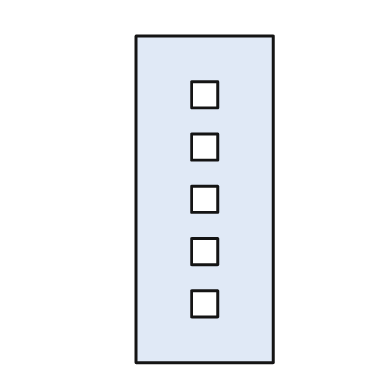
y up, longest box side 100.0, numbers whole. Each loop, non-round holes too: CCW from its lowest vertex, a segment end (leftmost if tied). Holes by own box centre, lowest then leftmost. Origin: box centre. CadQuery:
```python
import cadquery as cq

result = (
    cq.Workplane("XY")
    .moveTo(-21.0, -50.0)
    .lineTo(21.0, -50.0)
    .lineTo(21.0, 50.0)
    .lineTo(-21.0, 50.0)
    .close()
    .moveTo(-4.0, -36.0)
    .lineTo(4.0, -36.0)
    .lineTo(4.0, -28.0)
    .lineTo(-4.0, -28.0)
    .close()
    .moveTo(-4.0, -20.0)
    .lineTo(4.0, -20.0)
    .lineTo(4.0, -12.0)
    .lineTo(-4.0, -12.0)
    .close()
    .moveTo(-4.0, -4.0)
    .lineTo(4.0, -4.0)
    .lineTo(4.0, 4.0)
    .lineTo(-4.0, 4.0)
    .close()
    .moveTo(-4.0, 12.0)
    .lineTo(4.0, 12.0)
    .lineTo(4.0, 20.0)
    .lineTo(-4.0, 20.0)
    .close()
    .moveTo(-4.0, 28.0)
    .lineTo(4.0, 28.0)
    .lineTo(4.0, 36.0)
    .lineTo(-4.0, 36.0)
    .close()
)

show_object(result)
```